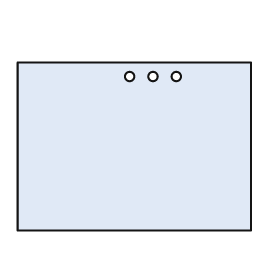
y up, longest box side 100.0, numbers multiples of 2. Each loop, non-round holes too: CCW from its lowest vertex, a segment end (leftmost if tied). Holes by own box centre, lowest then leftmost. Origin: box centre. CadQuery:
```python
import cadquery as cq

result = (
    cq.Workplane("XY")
    .moveTo(-50.0, -36.0)
    .lineTo(50.0, -36.0)
    .lineTo(50.0, 36.0)
    .lineTo(-50.0, 36.0)
    .close()
    .moveTo(-2.0, 30.0)
    .circle(2.0)
    .moveTo(8.0, 30.0)
    .circle(2.0)
    .moveTo(18.0, 30.0)
    .circle(2.0)
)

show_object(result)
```